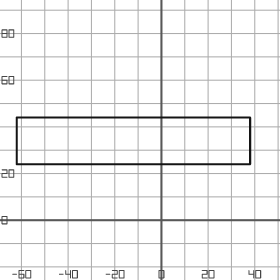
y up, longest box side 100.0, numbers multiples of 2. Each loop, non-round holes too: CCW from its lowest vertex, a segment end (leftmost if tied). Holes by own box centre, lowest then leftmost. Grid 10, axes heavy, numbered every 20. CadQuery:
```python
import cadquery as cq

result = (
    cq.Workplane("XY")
    .moveTo(-62.0, 24.0)
    .lineTo(38.0, 24.0)
    .lineTo(38.0, 44.0)
    .lineTo(-62.0, 44.0)
    .close()
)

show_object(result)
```